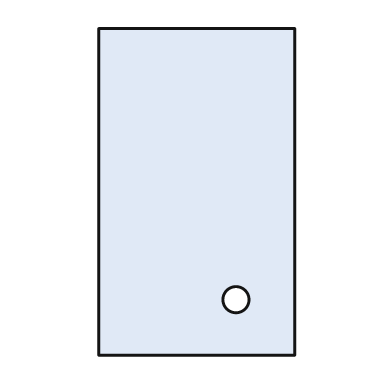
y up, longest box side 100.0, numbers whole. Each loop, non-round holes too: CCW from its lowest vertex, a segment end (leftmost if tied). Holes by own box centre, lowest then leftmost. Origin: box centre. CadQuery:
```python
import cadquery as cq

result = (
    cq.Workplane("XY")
    .moveTo(-30.0, -50.0)
    .lineTo(30.0, -50.0)
    .lineTo(30.0, 50.0)
    .lineTo(-30.0, 50.0)
    .close()
    .moveTo(12.0, -33.0)
    .circle(4.0)
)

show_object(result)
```